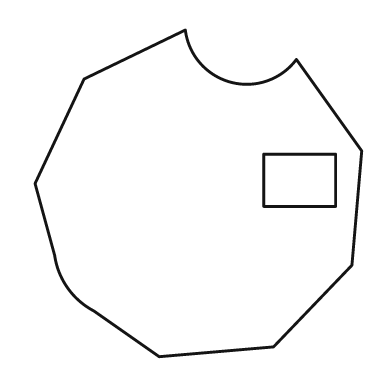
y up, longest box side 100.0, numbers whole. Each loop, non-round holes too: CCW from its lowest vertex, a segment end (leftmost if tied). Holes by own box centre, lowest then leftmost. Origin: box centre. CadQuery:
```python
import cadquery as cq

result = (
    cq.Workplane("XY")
    .moveTo(-12.0, -50.0)
    .lineTo(23.0, -47.0)
    .lineTo(47.0, -22.0)
    .lineTo(50.0, 13.0)
    .lineTo(30.0, 41.0)
    .threePointArc((10.0, 34.0), (-4.0, 50.0))
    .lineTo(-35.0, 35.0)
    .lineTo(-50.0, 3.0)
    .lineTo(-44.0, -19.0)
    .threePointArc((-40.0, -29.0), (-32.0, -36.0))
    .close()
    .moveTo(20.0, -4.0)
    .lineTo(42.0, -4.0)
    .lineTo(42.0, 12.0)
    .lineTo(20.0, 12.0)
    .close()
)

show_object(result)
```